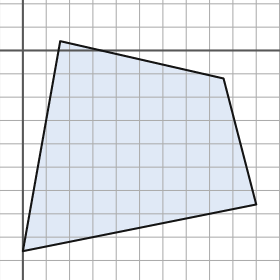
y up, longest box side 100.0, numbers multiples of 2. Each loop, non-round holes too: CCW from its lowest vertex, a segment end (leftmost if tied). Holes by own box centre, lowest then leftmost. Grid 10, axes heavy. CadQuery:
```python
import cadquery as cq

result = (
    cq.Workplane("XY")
    .moveTo(0.0, -86.0)
    .lineTo(100.0, -66.0)
    .lineTo(86.0, -12.0)
    .lineTo(16.0, 4.0)
    .close()
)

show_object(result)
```